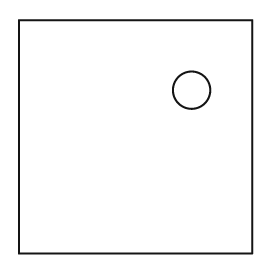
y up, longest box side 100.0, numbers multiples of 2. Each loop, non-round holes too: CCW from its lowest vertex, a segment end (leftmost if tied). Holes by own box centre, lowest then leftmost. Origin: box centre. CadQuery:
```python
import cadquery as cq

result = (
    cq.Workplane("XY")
    .moveTo(-50.0, -50.0)
    .lineTo(50.0, -50.0)
    .lineTo(50.0, 50.0)
    .lineTo(-50.0, 50.0)
    .close()
    .moveTo(24.0, 20.0)
    .circle(8.0)
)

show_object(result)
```